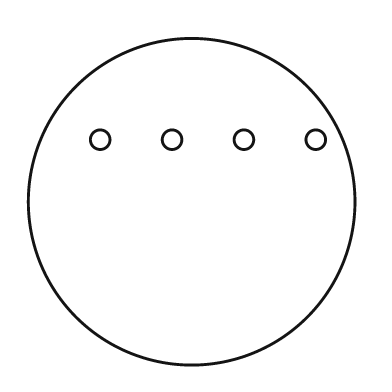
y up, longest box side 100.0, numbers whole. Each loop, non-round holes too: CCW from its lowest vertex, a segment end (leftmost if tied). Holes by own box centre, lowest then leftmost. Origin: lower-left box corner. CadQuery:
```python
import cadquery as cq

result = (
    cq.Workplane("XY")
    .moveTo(50.0, 50.0)
    .circle(50.0)
    .moveTo(22.0, 69.0)
    .circle(3.0)
    .moveTo(44.0, 69.0)
    .circle(3.0)
    .moveTo(66.0, 69.0)
    .circle(3.0)
    .moveTo(88.0, 69.0)
    .circle(3.0)
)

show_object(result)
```